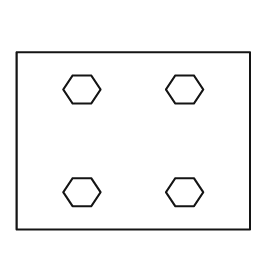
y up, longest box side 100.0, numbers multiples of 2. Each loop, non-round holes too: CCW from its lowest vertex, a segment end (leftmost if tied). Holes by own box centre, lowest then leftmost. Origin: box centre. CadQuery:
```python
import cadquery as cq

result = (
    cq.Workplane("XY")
    .moveTo(-50.0, -38.0)
    .lineTo(50.0, -38.0)
    .lineTo(50.0, 38.0)
    .lineTo(-50.0, 38.0)
    .close()
    .moveTo(-26.0, -28.0)
    .lineTo(-18.0, -28.0)
    .lineTo(-14.0, -22.0)
    .lineTo(-18.0, -16.0)
    .lineTo(-26.0, -16.0)
    .lineTo(-30.0, -22.0)
    .close()
    .moveTo(18.0, -28.0)
    .lineTo(26.0, -28.0)
    .lineTo(30.0, -22.0)
    .lineTo(26.0, -16.0)
    .lineTo(18.0, -16.0)
    .lineTo(14.0, -22.0)
    .close()
    .moveTo(-26.0, 16.0)
    .lineTo(-18.0, 16.0)
    .lineTo(-14.0, 22.0)
    .lineTo(-18.0, 28.0)
    .lineTo(-26.0, 28.0)
    .lineTo(-30.0, 22.0)
    .close()
    .moveTo(18.0, 16.0)
    .lineTo(26.0, 16.0)
    .lineTo(30.0, 22.0)
    .lineTo(26.0, 28.0)
    .lineTo(18.0, 28.0)
    .lineTo(14.0, 22.0)
    .close()
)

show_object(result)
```